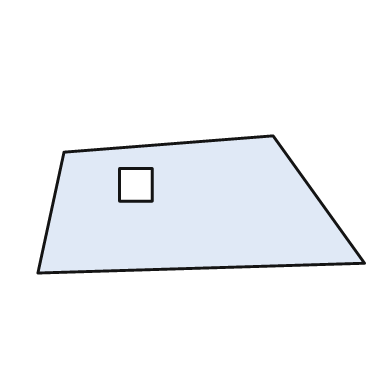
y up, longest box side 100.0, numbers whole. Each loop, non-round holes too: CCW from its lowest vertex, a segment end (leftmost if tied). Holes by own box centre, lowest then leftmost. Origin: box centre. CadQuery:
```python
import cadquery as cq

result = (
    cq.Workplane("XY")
    .moveTo(-50.0, -21.0)
    .lineTo(50.0, -18.0)
    .lineTo(22.0, 21.0)
    .lineTo(-42.0, 16.0)
    .close()
    .moveTo(-25.0, 1.0)
    .lineTo(-15.0, 1.0)
    .lineTo(-15.0, 11.0)
    .lineTo(-25.0, 11.0)
    .close()
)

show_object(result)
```